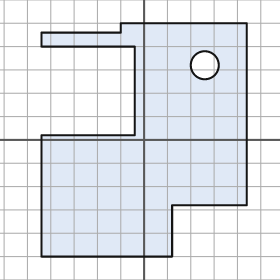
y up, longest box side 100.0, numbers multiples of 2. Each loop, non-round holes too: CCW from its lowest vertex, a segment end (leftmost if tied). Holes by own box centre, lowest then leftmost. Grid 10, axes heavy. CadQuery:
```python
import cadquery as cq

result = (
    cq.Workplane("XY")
    .moveTo(-44.0, -50.0)
    .lineTo(12.0, -50.0)
    .lineTo(12.0, -28.0)
    .lineTo(44.0, -28.0)
    .lineTo(44.0, 50.0)
    .lineTo(-10.0, 50.0)
    .lineTo(-10.0, 46.0)
    .lineTo(-44.0, 46.0)
    .lineTo(-44.0, 40.0)
    .lineTo(-4.0, 40.0)
    .lineTo(-4.0, 2.0)
    .lineTo(-44.0, 2.0)
    .close()
    .moveTo(26.0, 32.0)
    .circle(6.0)
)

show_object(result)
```